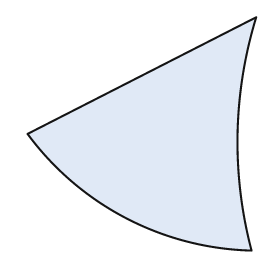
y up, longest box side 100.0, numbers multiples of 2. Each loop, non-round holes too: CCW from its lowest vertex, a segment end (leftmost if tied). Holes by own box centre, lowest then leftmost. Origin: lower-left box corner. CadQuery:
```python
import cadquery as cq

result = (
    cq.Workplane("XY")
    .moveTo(96.0, 0.0)
    .threePointArc((90.0, 50.0), (98.0, 100.0))
    .lineTo(0.0, 50.0)
    .threePointArc((42.0, 14.0), (96.0, 0.0))
    .close()
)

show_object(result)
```